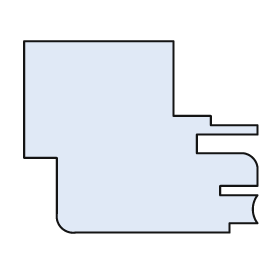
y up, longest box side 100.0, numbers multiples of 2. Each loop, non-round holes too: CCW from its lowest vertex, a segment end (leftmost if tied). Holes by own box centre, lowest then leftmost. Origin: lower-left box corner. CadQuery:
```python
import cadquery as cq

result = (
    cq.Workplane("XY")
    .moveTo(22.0, 0.0)
    .lineTo(88.0, 0.0)
    .lineTo(88.0, 4.0)
    .lineTo(100.0, 4.0)
    .threePointArc((98.0, 10.0), (100.0, 16.0))
    .lineTo(84.0, 16.0)
    .lineTo(84.0, 20.0)
    .lineTo(100.0, 20.0)
    .lineTo(100.0, 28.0)
    .threePointArc((98.0, 32.0), (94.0, 34.0))
    .lineTo(74.0, 34.0)
    .lineTo(74.0, 42.0)
    .lineTo(100.0, 42.0)
    .lineTo(100.0, 46.0)
    .lineTo(80.0, 46.0)
    .lineTo(80.0, 50.0)
    .lineTo(64.0, 50.0)
    .lineTo(64.0, 82.0)
    .lineTo(0.0, 82.0)
    .lineTo(0.0, 32.0)
    .lineTo(14.0, 32.0)
    .lineTo(14.0, 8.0)
    .threePointArc((16.0, 2.0), (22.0, 0.0))
    .close()
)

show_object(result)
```